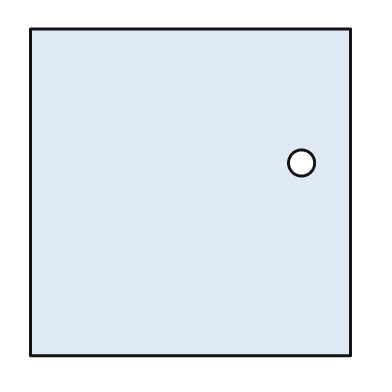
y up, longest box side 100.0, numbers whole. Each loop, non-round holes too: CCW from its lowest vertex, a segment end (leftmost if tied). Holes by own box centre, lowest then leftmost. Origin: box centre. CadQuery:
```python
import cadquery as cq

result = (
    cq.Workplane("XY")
    .moveTo(-49.0, -50.0)
    .lineTo(49.0, -50.0)
    .lineTo(49.0, 50.0)
    .lineTo(-49.0, 50.0)
    .close()
    .moveTo(34.0, 9.0)
    .circle(4.0)
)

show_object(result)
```